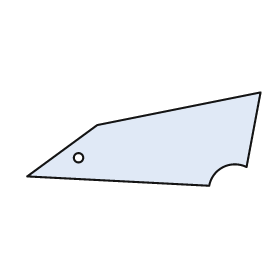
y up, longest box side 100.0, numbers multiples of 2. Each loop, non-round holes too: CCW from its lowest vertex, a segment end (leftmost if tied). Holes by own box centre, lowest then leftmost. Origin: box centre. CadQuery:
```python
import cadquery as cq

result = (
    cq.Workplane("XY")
    .moveTo(28.0, -20.0)
    .threePointArc((34.0, -12.0), (44.0, -12.0))
    .lineTo(50.0, 20.0)
    .lineTo(-20.0, 6.0)
    .lineTo(-50.0, -16.0)
    .close()
    .moveTo(-28.0, -8.0)
    .circle(2.0)
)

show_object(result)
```